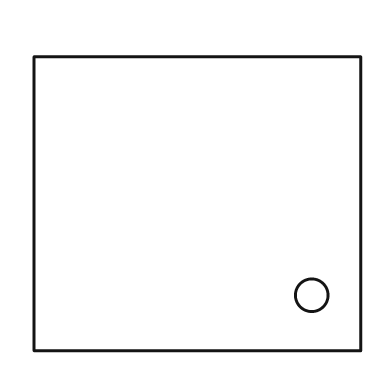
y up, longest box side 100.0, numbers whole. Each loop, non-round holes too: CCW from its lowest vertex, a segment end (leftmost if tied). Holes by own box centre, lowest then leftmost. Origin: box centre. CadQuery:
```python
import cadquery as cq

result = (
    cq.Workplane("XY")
    .moveTo(-50.0, -45.0)
    .lineTo(50.0, -45.0)
    .lineTo(50.0, 45.0)
    .lineTo(-50.0, 45.0)
    .close()
    .moveTo(35.0, -28.0)
    .circle(5.0)
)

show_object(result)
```